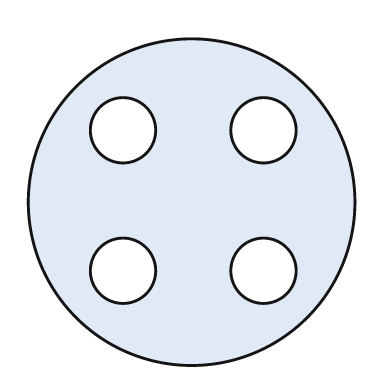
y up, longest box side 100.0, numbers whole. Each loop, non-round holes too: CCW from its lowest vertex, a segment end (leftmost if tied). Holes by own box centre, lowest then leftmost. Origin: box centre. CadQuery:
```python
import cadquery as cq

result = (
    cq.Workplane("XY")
    .moveTo(0.0, 0.0)
    .circle(50.0)
    .moveTo(-21.0, -21.0)
    .circle(10.0)
    .moveTo(22.0, -21.0)
    .circle(10.0)
    .moveTo(-21.0, 22.0)
    .circle(10.0)
    .moveTo(22.0, 22.0)
    .circle(10.0)
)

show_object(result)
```